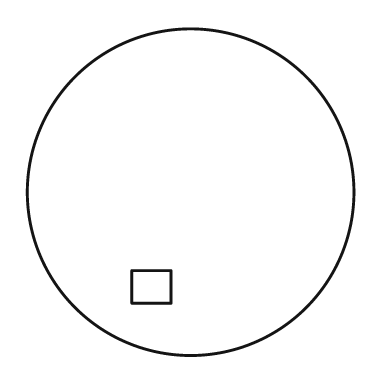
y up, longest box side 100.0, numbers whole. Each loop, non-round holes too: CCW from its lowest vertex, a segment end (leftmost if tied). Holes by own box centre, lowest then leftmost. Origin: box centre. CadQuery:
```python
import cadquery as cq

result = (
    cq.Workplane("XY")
    .moveTo(0.0, 0.0)
    .circle(50.0)
    .moveTo(-18.0, -34.0)
    .lineTo(-6.0, -34.0)
    .lineTo(-6.0, -24.0)
    .lineTo(-18.0, -24.0)
    .close()
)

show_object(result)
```